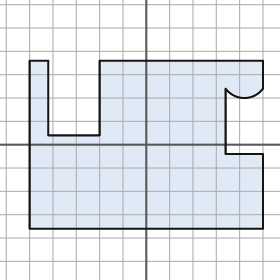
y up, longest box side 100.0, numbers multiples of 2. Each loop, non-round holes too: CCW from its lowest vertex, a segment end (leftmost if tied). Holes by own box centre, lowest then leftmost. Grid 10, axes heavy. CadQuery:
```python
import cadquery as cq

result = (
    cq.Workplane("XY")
    .moveTo(-50.0, -36.0)
    .lineTo(50.0, -36.0)
    .lineTo(50.0, -4.0)
    .lineTo(34.0, -4.0)
    .lineTo(34.0, 24.0)
    .threePointArc((42.0, 20.0), (50.0, 24.0))
    .lineTo(50.0, 36.0)
    .lineTo(-20.0, 36.0)
    .lineTo(-20.0, 4.0)
    .lineTo(-42.0, 4.0)
    .lineTo(-42.0, 36.0)
    .lineTo(-50.0, 36.0)
    .close()
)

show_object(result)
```